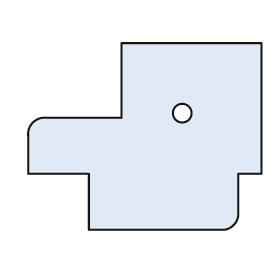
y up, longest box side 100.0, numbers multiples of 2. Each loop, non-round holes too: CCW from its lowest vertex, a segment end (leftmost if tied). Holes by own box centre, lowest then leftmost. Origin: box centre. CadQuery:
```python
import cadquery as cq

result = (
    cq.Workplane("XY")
    .moveTo(-24.0, -40.0)
    .lineTo(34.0, -40.0)
    .threePointArc((38.0, -38.0), (40.0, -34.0))
    .lineTo(40.0, -16.0)
    .lineTo(50.0, -16.0)
    .lineTo(50.0, 40.0)
    .lineTo(-10.0, 40.0)
    .lineTo(-10.0, 8.0)
    .lineTo(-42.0, 8.0)
    .threePointArc((-48.0, 6.0), (-50.0, 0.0))
    .lineTo(-50.0, -16.0)
    .lineTo(-24.0, -16.0)
    .close()
    .moveTo(16.0, 10.0)
    .circle(4.0)
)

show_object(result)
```